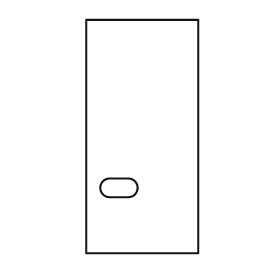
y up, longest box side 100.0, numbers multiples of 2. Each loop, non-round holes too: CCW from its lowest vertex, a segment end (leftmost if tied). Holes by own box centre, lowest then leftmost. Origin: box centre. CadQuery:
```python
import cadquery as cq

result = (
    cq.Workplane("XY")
    .moveTo(-24.0, -50.0)
    .lineTo(24.0, -50.0)
    .lineTo(24.0, 50.0)
    .lineTo(-24.0, 50.0)
    .close()
    .moveTo(-14.0, -26.0)
    .lineTo(-6.0, -26.0)
    .threePointArc((-2.0, -22.0), (-6.0, -18.0))
    .lineTo(-14.0, -18.0)
    .threePointArc((-18.0, -22.0), (-14.0, -26.0))
    .close()
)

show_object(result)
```